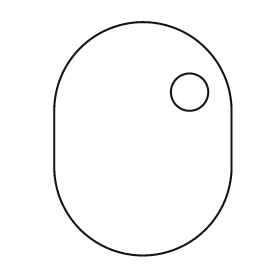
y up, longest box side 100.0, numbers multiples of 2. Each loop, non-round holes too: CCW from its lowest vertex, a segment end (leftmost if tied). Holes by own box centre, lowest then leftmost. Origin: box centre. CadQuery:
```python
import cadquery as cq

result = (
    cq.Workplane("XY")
    .moveTo(-38.0, -12.0)
    .threePointArc((0.0, -50.0), (38.0, -12.0))
    .lineTo(38.0, 12.0)
    .threePointArc((0.0, 50.0), (-38.0, 12.0))
    .close()
    .moveTo(20.0, 20.0)
    .circle(8.0)
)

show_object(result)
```